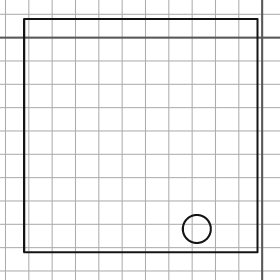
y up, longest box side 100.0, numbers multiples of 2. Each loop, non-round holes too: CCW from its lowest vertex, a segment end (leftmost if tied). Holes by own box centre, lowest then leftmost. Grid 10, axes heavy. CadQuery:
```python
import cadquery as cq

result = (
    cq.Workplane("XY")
    .moveTo(-102.0, -92.0)
    .lineTo(-2.0, -92.0)
    .lineTo(-2.0, 8.0)
    .lineTo(-102.0, 8.0)
    .close()
    .moveTo(-28.0, -82.0)
    .circle(6.0)
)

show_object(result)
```